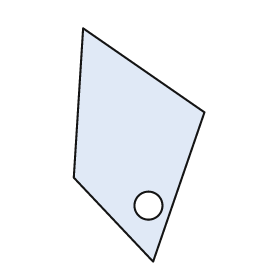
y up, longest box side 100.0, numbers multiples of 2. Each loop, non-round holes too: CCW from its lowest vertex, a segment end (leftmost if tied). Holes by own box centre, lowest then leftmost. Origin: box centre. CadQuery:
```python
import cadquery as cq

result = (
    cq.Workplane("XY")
    .moveTo(6.0, -50.0)
    .lineTo(28.0, 14.0)
    .lineTo(-24.0, 50.0)
    .lineTo(-28.0, -14.0)
    .close()
    .moveTo(4.0, -26.0)
    .circle(6.0)
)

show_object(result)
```